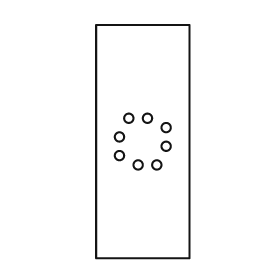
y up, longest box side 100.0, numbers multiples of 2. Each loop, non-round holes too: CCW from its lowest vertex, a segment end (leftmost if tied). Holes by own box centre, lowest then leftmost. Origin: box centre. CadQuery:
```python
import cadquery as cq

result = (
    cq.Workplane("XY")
    .moveTo(-20.0, -50.0)
    .lineTo(20.0, -50.0)
    .lineTo(20.0, 50.0)
    .lineTo(-20.0, 50.0)
    .close()
    .moveTo(-2.0, -10.0)
    .circle(2.0)
    .moveTo(6.0, -10.0)
    .circle(2.0)
    .moveTo(-10.0, -6.0)
    .circle(2.0)
    .moveTo(10.0, -2.0)
    .circle(2.0)
    .moveTo(-10.0, 2.0)
    .circle(2.0)
    .moveTo(10.0, 6.0)
    .circle(2.0)
    .moveTo(-6.0, 10.0)
    .circle(2.0)
    .moveTo(2.0, 10.0)
    .circle(2.0)
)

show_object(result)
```